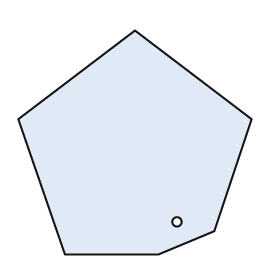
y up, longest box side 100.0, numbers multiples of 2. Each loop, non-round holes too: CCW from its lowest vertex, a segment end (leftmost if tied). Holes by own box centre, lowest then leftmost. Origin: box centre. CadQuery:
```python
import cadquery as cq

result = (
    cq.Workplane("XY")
    .moveTo(-30.0, -48.0)
    .lineTo(10.0, -48.0)
    .lineTo(34.0, -38.0)
    .lineTo(50.0, 10.0)
    .lineTo(0.0, 48.0)
    .lineTo(-50.0, 10.0)
    .close()
    .moveTo(18.0, -34.0)
    .circle(2.0)
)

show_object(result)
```